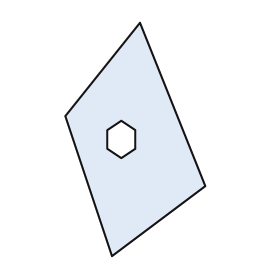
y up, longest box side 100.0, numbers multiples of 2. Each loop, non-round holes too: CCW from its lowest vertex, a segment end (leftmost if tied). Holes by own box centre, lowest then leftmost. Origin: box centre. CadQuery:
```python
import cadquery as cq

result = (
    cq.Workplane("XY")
    .moveTo(-10.0, -50.0)
    .lineTo(30.0, -20.0)
    .lineTo(2.0, 50.0)
    .lineTo(-30.0, 10.0)
    .close()
    .moveTo(-6.0, -8.0)
    .lineTo(0.0, -4.0)
    .lineTo(0.0, 4.0)
    .lineTo(-6.0, 8.0)
    .lineTo(-12.0, 4.0)
    .lineTo(-12.0, -4.0)
    .close()
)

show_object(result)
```